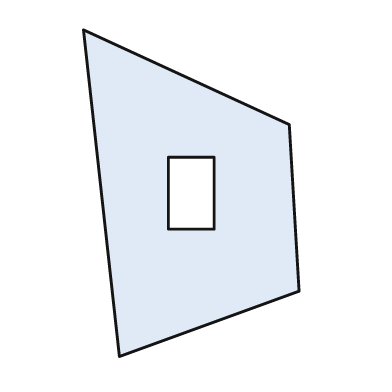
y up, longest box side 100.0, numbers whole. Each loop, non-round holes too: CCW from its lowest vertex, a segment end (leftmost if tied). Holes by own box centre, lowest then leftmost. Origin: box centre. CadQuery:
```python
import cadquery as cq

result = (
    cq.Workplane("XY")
    .moveTo(-22.0, -50.0)
    .lineTo(33.0, -30.0)
    .lineTo(30.0, 21.0)
    .lineTo(-33.0, 50.0)
    .close()
    .moveTo(-7.0, -11.0)
    .lineTo(7.0, -11.0)
    .lineTo(7.0, 11.0)
    .lineTo(-7.0, 11.0)
    .close()
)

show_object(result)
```